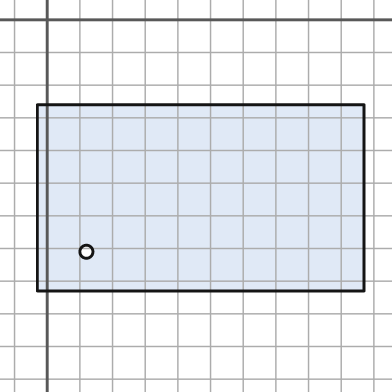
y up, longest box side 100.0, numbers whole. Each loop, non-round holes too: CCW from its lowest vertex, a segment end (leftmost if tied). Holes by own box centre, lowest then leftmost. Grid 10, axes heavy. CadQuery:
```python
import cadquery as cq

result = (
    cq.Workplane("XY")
    .moveTo(-3.0, -83.0)
    .lineTo(97.0, -83.0)
    .lineTo(97.0, -26.0)
    .lineTo(-3.0, -26.0)
    .close()
    .moveTo(12.0, -71.0)
    .circle(2.0)
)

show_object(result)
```